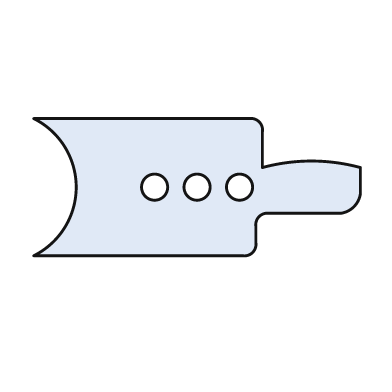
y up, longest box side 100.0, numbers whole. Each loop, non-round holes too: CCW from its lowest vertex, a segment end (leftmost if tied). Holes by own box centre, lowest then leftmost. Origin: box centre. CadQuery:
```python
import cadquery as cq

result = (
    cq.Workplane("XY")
    .moveTo(-50.0, -21.0)
    .lineTo(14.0, -21.0)
    .threePointArc((17.0, -20.0), (18.0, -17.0))
    .lineTo(18.0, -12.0)
    .threePointArc((19.0, -9.0), (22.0, -8.0))
    .lineTo(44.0, -8.0)
    .threePointArc((48.0, -6.0), (50.0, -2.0))
    .lineTo(50.0, 6.0)
    .threePointArc((35.0, 8.0), (20.0, 6.0))
    .lineTo(20.0, 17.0)
    .threePointArc((19.0, 20.0), (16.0, 21.0))
    .lineTo(-50.0, 21.0)
    .threePointArc((-37.0, 0.0), (-50.0, -21.0))
    .close()
    .moveTo(-13.0, 0.0)
    .circle(4.0)
    .moveTo(0.0, 0.0)
    .circle(4.0)
    .moveTo(13.0, 0.0)
    .circle(4.0)
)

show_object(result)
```